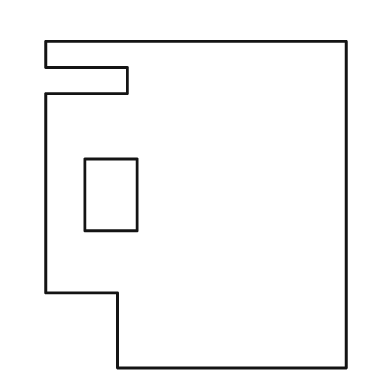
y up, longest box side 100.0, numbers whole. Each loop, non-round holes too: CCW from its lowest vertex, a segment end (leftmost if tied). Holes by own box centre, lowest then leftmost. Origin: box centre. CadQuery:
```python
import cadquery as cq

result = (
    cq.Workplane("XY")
    .moveTo(-24.0, -50.0)
    .lineTo(46.0, -50.0)
    .lineTo(46.0, 50.0)
    .lineTo(-46.0, 50.0)
    .lineTo(-46.0, 42.0)
    .lineTo(-21.0, 42.0)
    .lineTo(-21.0, 34.0)
    .lineTo(-46.0, 34.0)
    .lineTo(-46.0, -27.0)
    .lineTo(-24.0, -27.0)
    .close()
    .moveTo(-34.0, -8.0)
    .lineTo(-18.0, -8.0)
    .lineTo(-18.0, 14.0)
    .lineTo(-34.0, 14.0)
    .close()
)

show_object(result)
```